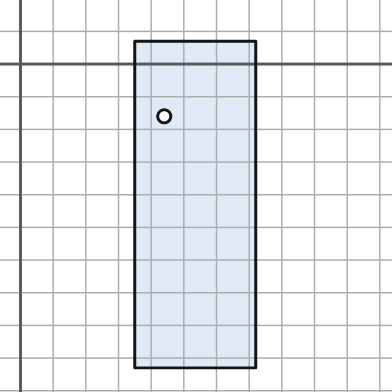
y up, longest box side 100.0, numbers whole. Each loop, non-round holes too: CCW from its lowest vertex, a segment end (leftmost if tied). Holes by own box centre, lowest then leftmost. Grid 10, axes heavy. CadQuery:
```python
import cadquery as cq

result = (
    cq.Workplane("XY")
    .moveTo(35.0, -93.0)
    .lineTo(72.0, -93.0)
    .lineTo(72.0, 7.0)
    .lineTo(35.0, 7.0)
    .close()
    .moveTo(44.0, -16.0)
    .circle(2.0)
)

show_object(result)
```